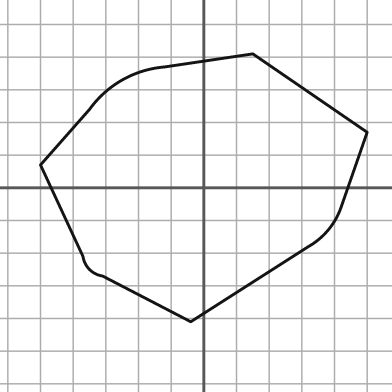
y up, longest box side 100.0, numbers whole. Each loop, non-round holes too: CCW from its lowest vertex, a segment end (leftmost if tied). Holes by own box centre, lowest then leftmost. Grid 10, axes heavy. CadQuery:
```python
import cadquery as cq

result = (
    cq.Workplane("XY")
    .moveTo(-4.0, -41.0)
    .lineTo(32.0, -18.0)
    .threePointArc((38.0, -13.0), (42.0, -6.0))
    .lineTo(50.0, 17.0)
    .lineTo(15.0, 41.0)
    .lineTo(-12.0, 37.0)
    .threePointArc((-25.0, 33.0), (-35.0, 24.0))
    .lineTo(-50.0, 7.0)
    .lineTo(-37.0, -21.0)
    .threePointArc((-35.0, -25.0), (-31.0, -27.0))
    .close()
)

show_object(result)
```